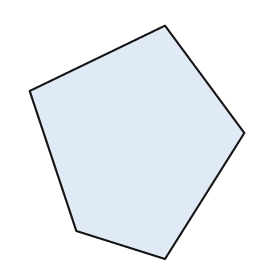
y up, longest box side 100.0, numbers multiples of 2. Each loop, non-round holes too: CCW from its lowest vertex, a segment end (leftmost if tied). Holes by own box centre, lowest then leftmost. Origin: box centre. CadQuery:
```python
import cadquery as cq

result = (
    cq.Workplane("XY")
    .moveTo(12.0, -50.0)
    .lineTo(46.0, 4.0)
    .lineTo(12.0, 50.0)
    .lineTo(-46.0, 22.0)
    .lineTo(-26.0, -38.0)
    .close()
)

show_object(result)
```